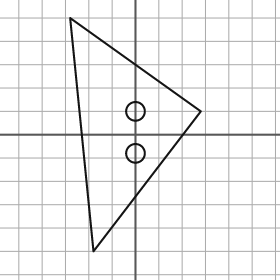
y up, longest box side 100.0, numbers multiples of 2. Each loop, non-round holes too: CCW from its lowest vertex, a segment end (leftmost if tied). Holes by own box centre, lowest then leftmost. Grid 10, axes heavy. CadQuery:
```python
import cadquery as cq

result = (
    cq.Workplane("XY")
    .moveTo(-18.0, -50.0)
    .lineTo(28.0, 10.0)
    .lineTo(-28.0, 50.0)
    .close()
    .moveTo(0.0, -8.0)
    .circle(4.0)
    .moveTo(0.0, 10.0)
    .circle(4.0)
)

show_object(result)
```